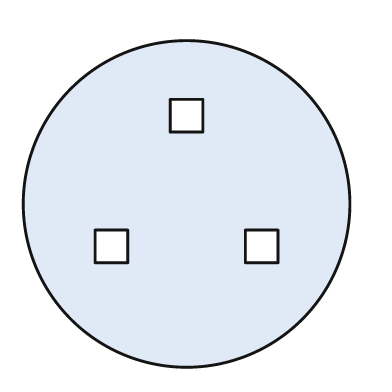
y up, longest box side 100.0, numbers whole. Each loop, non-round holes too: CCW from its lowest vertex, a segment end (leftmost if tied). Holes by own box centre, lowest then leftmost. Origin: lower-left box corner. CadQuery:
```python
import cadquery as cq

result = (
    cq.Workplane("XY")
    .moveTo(50.0, 50.0)
    .circle(50.0)
    .moveTo(22.0, 32.0)
    .lineTo(32.0, 32.0)
    .lineTo(32.0, 42.0)
    .lineTo(22.0, 42.0)
    .close()
    .moveTo(68.0, 32.0)
    .lineTo(78.0, 32.0)
    .lineTo(78.0, 42.0)
    .lineTo(68.0, 42.0)
    .close()
    .moveTo(45.0, 72.0)
    .lineTo(55.0, 72.0)
    .lineTo(55.0, 82.0)
    .lineTo(45.0, 82.0)
    .close()
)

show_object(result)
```